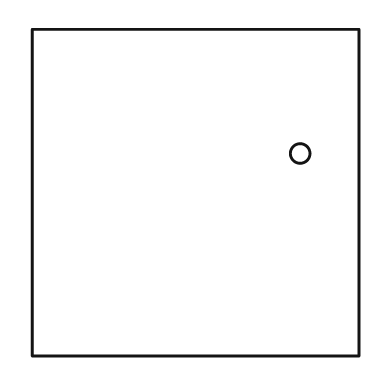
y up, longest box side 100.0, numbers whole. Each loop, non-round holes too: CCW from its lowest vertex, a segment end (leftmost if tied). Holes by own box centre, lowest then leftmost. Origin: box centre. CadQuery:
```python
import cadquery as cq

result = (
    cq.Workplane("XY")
    .moveTo(-50.0, -50.0)
    .lineTo(50.0, -50.0)
    .lineTo(50.0, 50.0)
    .lineTo(-50.0, 50.0)
    .close()
    .moveTo(32.0, 12.0)
    .circle(3.0)
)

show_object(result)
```